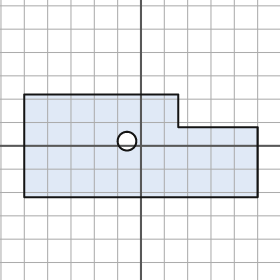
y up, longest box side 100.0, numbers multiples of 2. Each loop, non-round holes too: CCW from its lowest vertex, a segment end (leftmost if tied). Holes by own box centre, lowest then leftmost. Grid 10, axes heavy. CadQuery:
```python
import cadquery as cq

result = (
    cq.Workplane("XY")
    .moveTo(-50.0, -22.0)
    .lineTo(50.0, -22.0)
    .lineTo(50.0, 8.0)
    .lineTo(16.0, 8.0)
    .lineTo(16.0, 22.0)
    .lineTo(-50.0, 22.0)
    .close()
    .moveTo(-6.0, 2.0)
    .circle(4.0)
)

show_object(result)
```